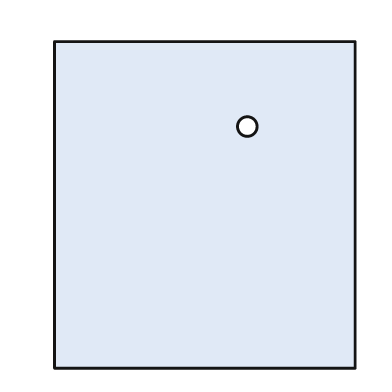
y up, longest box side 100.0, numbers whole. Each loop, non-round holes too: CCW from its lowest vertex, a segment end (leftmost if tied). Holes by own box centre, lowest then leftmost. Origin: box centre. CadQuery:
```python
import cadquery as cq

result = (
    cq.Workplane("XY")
    .moveTo(-46.0, -50.0)
    .lineTo(46.0, -50.0)
    .lineTo(46.0, 50.0)
    .lineTo(-46.0, 50.0)
    .close()
    .moveTo(13.0, 24.0)
    .circle(3.0)
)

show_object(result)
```